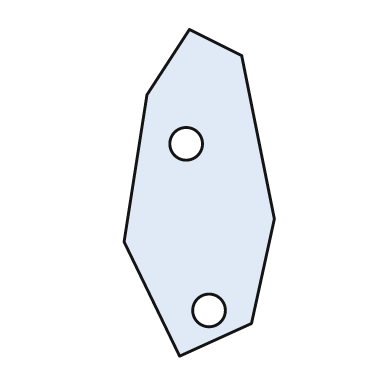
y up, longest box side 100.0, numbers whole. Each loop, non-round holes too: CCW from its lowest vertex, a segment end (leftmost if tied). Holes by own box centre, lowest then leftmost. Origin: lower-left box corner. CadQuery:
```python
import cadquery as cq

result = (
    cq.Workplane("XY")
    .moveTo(17.0, 0.0)
    .lineTo(39.0, 10.0)
    .lineTo(46.0, 42.0)
    .lineTo(36.0, 92.0)
    .lineTo(20.0, 100.0)
    .lineTo(7.0, 80.0)
    .lineTo(0.0, 35.0)
    .close()
    .moveTo(26.0, 14.0)
    .circle(5.0)
    .moveTo(19.0, 65.0)
    .circle(5.0)
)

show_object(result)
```